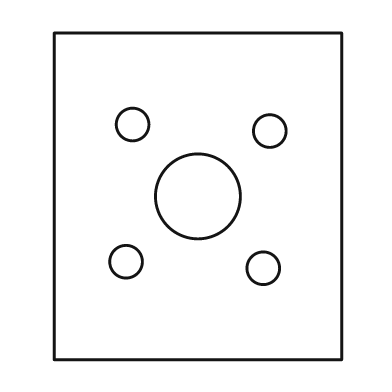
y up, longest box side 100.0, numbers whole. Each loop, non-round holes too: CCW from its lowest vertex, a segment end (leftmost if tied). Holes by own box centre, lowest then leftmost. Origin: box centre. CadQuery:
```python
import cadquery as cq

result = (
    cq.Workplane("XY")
    .moveTo(-44.0, -50.0)
    .lineTo(44.0, -50.0)
    .lineTo(44.0, 50.0)
    .lineTo(-44.0, 50.0)
    .close()
    .moveTo(20.0, -22.0)
    .circle(5.0)
    .moveTo(-22.0, -20.0)
    .circle(5.0)
    .moveTo(0.0, 0.0)
    .circle(13.0)
    .moveTo(22.0, 20.0)
    .circle(5.0)
    .moveTo(-20.0, 22.0)
    .circle(5.0)
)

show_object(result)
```